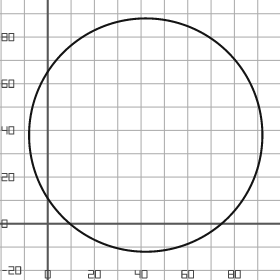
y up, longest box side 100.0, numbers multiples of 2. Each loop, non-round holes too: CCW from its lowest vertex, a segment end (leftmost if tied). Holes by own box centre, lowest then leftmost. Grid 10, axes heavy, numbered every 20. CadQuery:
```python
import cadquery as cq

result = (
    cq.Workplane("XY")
    .moveTo(42.0, 38.0)
    .circle(50.0)
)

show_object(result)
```